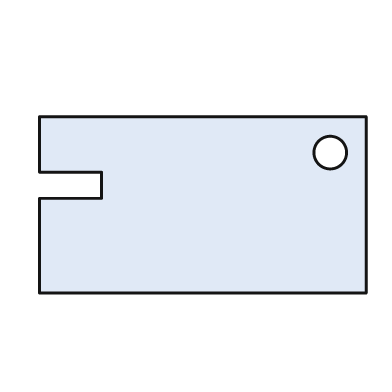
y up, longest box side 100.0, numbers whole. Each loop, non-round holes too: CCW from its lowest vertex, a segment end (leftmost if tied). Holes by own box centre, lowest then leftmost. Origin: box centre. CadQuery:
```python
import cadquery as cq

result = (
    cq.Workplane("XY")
    .moveTo(-50.0, -27.0)
    .lineTo(50.0, -27.0)
    .lineTo(50.0, 27.0)
    .lineTo(-50.0, 27.0)
    .lineTo(-50.0, 10.0)
    .lineTo(-31.0, 10.0)
    .lineTo(-31.0, 2.0)
    .lineTo(-50.0, 2.0)
    .close()
    .moveTo(39.0, 16.0)
    .circle(5.0)
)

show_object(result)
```